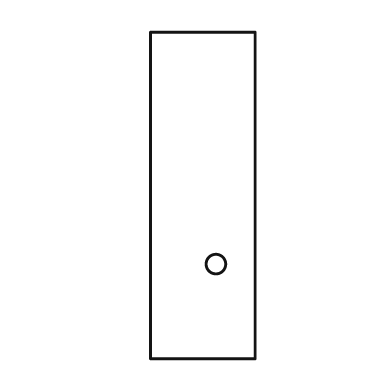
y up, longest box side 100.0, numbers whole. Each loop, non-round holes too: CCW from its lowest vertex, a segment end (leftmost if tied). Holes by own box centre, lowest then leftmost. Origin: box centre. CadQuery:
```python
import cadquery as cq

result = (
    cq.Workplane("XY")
    .moveTo(-16.0, -50.0)
    .lineTo(16.0, -50.0)
    .lineTo(16.0, 50.0)
    .lineTo(-16.0, 50.0)
    .close()
    .moveTo(4.0, -21.0)
    .circle(3.0)
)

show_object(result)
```